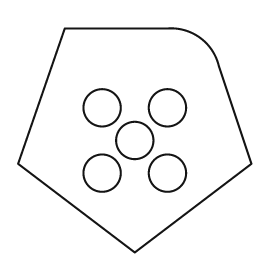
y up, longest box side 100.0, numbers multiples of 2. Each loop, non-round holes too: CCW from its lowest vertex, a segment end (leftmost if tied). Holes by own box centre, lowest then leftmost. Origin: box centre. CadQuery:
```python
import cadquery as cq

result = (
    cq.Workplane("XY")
    .moveTo(0.0, -48.0)
    .lineTo(50.0, -10.0)
    .lineTo(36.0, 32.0)
    .threePointArc((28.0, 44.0), (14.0, 48.0))
    .lineTo(-30.0, 48.0)
    .lineTo(-50.0, -10.0)
    .close()
    .moveTo(-14.0, -14.0)
    .circle(8.0)
    .moveTo(14.0, -14.0)
    .circle(8.0)
    .moveTo(0.0, 0.0)
    .circle(8.0)
    .moveTo(-14.0, 14.0)
    .circle(8.0)
    .moveTo(14.0, 14.0)
    .circle(8.0)
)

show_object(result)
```